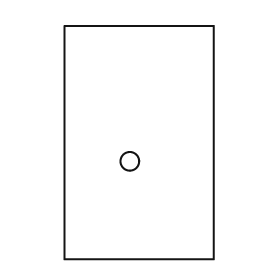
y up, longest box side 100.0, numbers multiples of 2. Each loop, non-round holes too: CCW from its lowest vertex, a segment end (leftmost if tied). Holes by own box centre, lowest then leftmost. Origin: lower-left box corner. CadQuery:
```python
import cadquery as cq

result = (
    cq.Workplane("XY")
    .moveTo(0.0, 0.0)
    .lineTo(64.0, 0.0)
    .lineTo(64.0, 100.0)
    .lineTo(0.0, 100.0)
    .close()
    .moveTo(28.0, 42.0)
    .circle(4.0)
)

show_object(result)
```